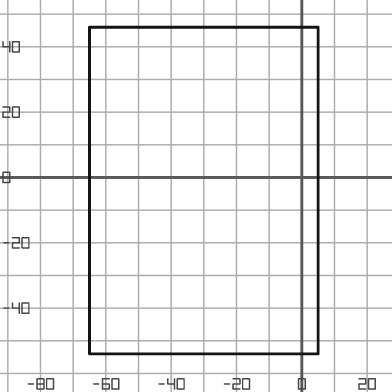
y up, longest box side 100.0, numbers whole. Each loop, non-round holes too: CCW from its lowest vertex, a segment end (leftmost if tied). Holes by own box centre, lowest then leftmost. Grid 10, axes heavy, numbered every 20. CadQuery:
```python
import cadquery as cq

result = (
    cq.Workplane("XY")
    .moveTo(-65.0, -54.0)
    .lineTo(5.0, -54.0)
    .lineTo(5.0, 46.0)
    .lineTo(-65.0, 46.0)
    .close()
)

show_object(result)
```